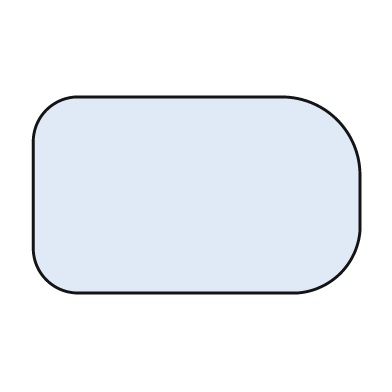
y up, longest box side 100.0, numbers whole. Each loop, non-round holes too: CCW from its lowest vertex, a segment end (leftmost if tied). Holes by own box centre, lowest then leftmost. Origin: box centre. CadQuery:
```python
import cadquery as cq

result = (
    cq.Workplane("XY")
    .moveTo(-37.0, -30.0)
    .lineTo(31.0, -30.0)
    .threePointArc((44.0, -24.0), (50.0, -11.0))
    .lineTo(50.0, 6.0)
    .threePointArc((43.0, 23.0), (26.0, 30.0))
    .lineTo(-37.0, 30.0)
    .threePointArc((-46.0, 26.0), (-50.0, 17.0))
    .lineTo(-50.0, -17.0)
    .threePointArc((-46.0, -26.0), (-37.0, -30.0))
    .close()
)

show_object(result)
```